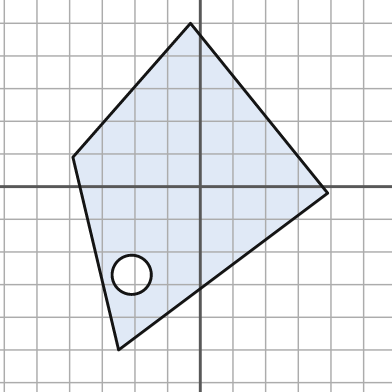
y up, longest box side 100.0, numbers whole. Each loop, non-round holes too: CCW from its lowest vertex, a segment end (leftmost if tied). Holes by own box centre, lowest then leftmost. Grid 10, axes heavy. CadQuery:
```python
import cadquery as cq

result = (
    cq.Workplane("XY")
    .moveTo(-25.0, -50.0)
    .lineTo(39.0, -2.0)
    .lineTo(-3.0, 50.0)
    .lineTo(-39.0, 9.0)
    .close()
    .moveTo(-21.0, -27.0)
    .circle(6.0)
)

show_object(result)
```